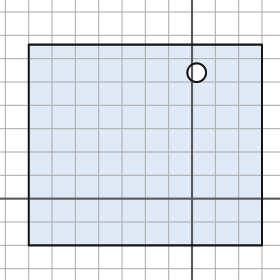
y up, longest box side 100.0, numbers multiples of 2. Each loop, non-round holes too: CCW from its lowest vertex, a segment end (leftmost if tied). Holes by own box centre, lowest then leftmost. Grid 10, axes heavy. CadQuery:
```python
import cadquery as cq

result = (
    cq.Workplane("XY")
    .moveTo(-70.0, -20.0)
    .lineTo(30.0, -20.0)
    .lineTo(30.0, 66.0)
    .lineTo(-70.0, 66.0)
    .close()
    .moveTo(2.0, 54.0)
    .circle(4.0)
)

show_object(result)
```